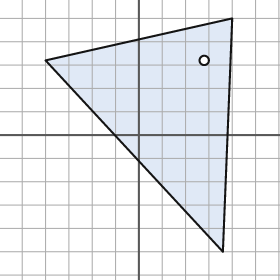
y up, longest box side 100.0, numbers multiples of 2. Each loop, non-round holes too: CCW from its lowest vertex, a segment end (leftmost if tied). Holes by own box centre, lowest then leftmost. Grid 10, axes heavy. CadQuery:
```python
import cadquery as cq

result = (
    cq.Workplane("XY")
    .moveTo(36.0, -50.0)
    .lineTo(40.0, 50.0)
    .lineTo(-40.0, 32.0)
    .close()
    .moveTo(28.0, 32.0)
    .circle(2.0)
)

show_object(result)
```